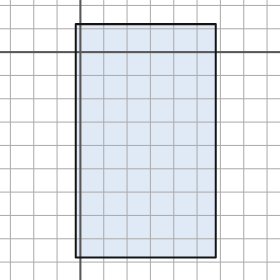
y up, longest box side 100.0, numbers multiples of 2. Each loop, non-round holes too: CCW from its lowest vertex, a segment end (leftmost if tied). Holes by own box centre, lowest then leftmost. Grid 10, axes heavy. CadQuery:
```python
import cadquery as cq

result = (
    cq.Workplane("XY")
    .moveTo(-2.0, -88.0)
    .lineTo(58.0, -88.0)
    .lineTo(58.0, 12.0)
    .lineTo(-2.0, 12.0)
    .close()
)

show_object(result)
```